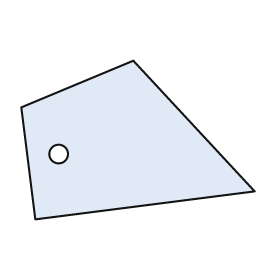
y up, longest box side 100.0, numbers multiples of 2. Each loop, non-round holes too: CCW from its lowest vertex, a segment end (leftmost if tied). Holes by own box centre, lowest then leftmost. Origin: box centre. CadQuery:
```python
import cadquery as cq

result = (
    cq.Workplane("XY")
    .moveTo(-44.0, -34.0)
    .lineTo(50.0, -22.0)
    .lineTo(-2.0, 34.0)
    .lineTo(-50.0, 14.0)
    .close()
    .moveTo(-34.0, -6.0)
    .circle(4.0)
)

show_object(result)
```